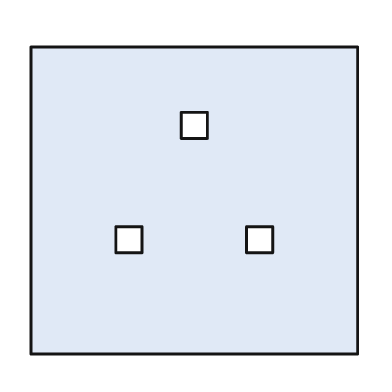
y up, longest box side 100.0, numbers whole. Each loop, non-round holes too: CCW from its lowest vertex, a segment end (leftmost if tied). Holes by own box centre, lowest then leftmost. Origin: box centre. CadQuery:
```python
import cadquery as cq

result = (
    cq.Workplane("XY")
    .moveTo(-50.0, -47.0)
    .lineTo(50.0, -47.0)
    .lineTo(50.0, 47.0)
    .lineTo(-50.0, 47.0)
    .close()
    .moveTo(-24.0, -16.0)
    .lineTo(-16.0, -16.0)
    .lineTo(-16.0, -8.0)
    .lineTo(-24.0, -8.0)
    .close()
    .moveTo(16.0, -16.0)
    .lineTo(24.0, -16.0)
    .lineTo(24.0, -8.0)
    .lineTo(16.0, -8.0)
    .close()
    .moveTo(-4.0, 19.0)
    .lineTo(4.0, 19.0)
    .lineTo(4.0, 27.0)
    .lineTo(-4.0, 27.0)
    .close()
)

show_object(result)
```